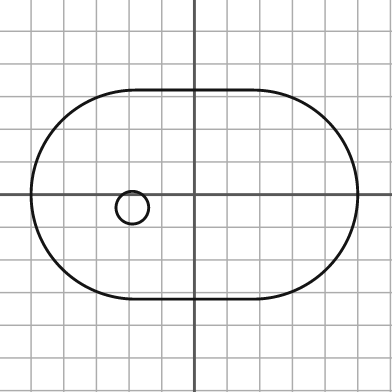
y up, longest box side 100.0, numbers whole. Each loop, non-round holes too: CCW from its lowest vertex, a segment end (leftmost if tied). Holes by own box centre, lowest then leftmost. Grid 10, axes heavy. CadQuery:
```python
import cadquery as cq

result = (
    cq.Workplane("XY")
    .moveTo(-18.0, -32.0)
    .lineTo(18.0, -32.0)
    .threePointArc((50.0, 0.0), (18.0, 32.0))
    .lineTo(-18.0, 32.0)
    .threePointArc((-50.0, 0.0), (-18.0, -32.0))
    .close()
    .moveTo(-19.0, -4.0)
    .circle(5.0)
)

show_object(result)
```